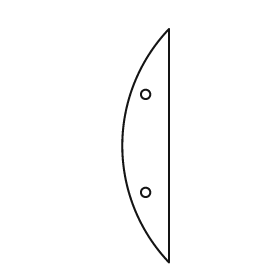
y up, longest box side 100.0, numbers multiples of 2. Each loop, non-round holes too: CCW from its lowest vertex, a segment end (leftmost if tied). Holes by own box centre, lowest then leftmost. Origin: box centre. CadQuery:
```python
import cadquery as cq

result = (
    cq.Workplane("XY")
    .moveTo(10.0, -50.0)
    .lineTo(10.0, 50.0)
    .threePointArc((-10.0, 0.0), (10.0, -50.0))
    .close()
    .moveTo(0.0, -20.0)
    .circle(2.0)
    .moveTo(0.0, 22.0)
    .circle(2.0)
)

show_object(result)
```